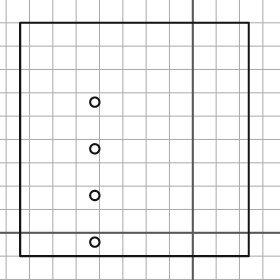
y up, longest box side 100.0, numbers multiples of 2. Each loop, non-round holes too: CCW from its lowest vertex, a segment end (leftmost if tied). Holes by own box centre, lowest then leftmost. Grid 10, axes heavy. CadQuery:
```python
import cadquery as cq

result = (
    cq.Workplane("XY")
    .moveTo(-74.0, -10.0)
    .lineTo(24.0, -10.0)
    .lineTo(24.0, 90.0)
    .lineTo(-74.0, 90.0)
    .close()
    .moveTo(-42.0, -4.0)
    .circle(2.0)
    .moveTo(-42.0, 16.0)
    .circle(2.0)
    .moveTo(-42.0, 36.0)
    .circle(2.0)
    .moveTo(-42.0, 56.0)
    .circle(2.0)
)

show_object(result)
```